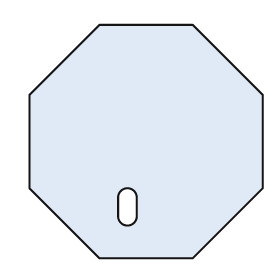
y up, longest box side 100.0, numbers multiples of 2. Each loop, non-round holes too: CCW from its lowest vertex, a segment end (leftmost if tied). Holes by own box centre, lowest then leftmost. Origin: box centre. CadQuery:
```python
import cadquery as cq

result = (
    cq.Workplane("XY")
    .moveTo(-20.0, -50.0)
    .lineTo(20.0, -50.0)
    .lineTo(50.0, -20.0)
    .lineTo(50.0, 20.0)
    .lineTo(20.0, 50.0)
    .lineTo(-20.0, 50.0)
    .lineTo(-50.0, 20.0)
    .lineTo(-50.0, -20.0)
    .close()
    .moveTo(-12.0, -32.0)
    .threePointArc((-8.0, -36.0), (-4.0, -32.0))
    .lineTo(-4.0, -24.0)
    .threePointArc((-8.0, -20.0), (-12.0, -24.0))
    .close()
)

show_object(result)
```